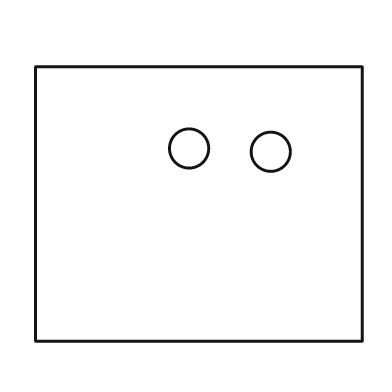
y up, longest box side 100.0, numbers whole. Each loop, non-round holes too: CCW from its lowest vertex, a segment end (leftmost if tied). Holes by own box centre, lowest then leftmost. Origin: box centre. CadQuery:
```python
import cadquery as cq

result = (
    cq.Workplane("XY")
    .moveTo(-50.0, -42.0)
    .lineTo(50.0, -42.0)
    .lineTo(50.0, 42.0)
    .lineTo(-50.0, 42.0)
    .close()
    .moveTo(22.0, 16.0)
    .circle(6.0)
    .moveTo(-3.0, 17.0)
    .circle(6.0)
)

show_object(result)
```